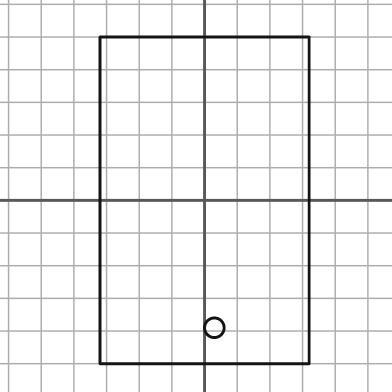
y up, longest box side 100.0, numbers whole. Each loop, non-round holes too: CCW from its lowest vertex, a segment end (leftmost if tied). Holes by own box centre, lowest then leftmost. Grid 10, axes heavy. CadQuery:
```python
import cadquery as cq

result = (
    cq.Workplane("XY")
    .moveTo(-32.0, -50.0)
    .lineTo(32.0, -50.0)
    .lineTo(32.0, 50.0)
    .lineTo(-32.0, 50.0)
    .close()
    .moveTo(3.0, -39.0)
    .circle(3.0)
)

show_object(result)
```